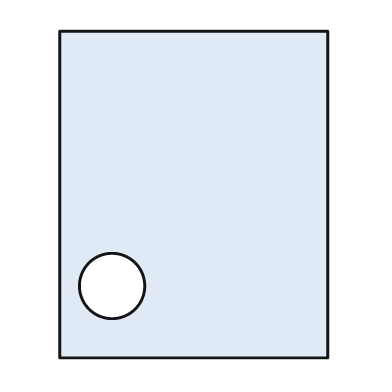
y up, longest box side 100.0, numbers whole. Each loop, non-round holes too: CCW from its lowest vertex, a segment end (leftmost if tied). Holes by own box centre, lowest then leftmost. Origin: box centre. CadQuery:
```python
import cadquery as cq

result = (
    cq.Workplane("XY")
    .moveTo(-41.0, -50.0)
    .lineTo(41.0, -50.0)
    .lineTo(41.0, 50.0)
    .lineTo(-41.0, 50.0)
    .close()
    .moveTo(-25.0, -28.0)
    .circle(10.0)
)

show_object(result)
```